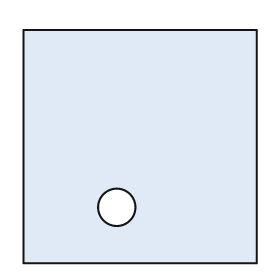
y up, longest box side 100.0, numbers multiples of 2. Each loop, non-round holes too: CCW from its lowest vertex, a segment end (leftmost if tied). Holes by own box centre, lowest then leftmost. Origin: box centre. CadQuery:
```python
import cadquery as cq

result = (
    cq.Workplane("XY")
    .moveTo(-50.0, -50.0)
    .lineTo(50.0, -50.0)
    .lineTo(50.0, 50.0)
    .lineTo(-50.0, 50.0)
    .close()
    .moveTo(-10.0, -26.0)
    .circle(8.0)
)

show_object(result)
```